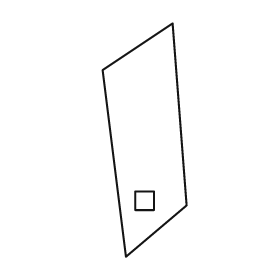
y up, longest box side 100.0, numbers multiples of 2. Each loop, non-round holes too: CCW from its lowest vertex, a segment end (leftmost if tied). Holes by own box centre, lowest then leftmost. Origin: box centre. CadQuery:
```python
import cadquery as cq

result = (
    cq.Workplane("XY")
    .moveTo(-8.0, -50.0)
    .lineTo(18.0, -28.0)
    .lineTo(12.0, 50.0)
    .lineTo(-18.0, 30.0)
    .close()
    .moveTo(-4.0, -30.0)
    .lineTo(4.0, -30.0)
    .lineTo(4.0, -22.0)
    .lineTo(-4.0, -22.0)
    .close()
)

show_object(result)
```